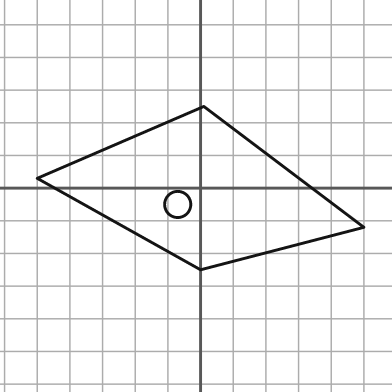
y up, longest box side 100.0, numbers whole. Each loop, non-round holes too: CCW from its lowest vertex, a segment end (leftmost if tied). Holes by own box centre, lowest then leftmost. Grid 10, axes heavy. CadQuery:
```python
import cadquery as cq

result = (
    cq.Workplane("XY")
    .moveTo(0.0, -25.0)
    .lineTo(50.0, -12.0)
    .lineTo(1.0, 25.0)
    .lineTo(-50.0, 3.0)
    .close()
    .moveTo(-7.0, -5.0)
    .circle(4.0)
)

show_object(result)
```